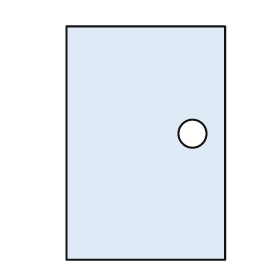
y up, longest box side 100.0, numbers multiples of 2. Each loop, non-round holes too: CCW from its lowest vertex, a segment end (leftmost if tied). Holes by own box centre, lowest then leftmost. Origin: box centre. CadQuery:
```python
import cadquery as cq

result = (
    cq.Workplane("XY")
    .moveTo(-34.0, -50.0)
    .lineTo(34.0, -50.0)
    .lineTo(34.0, 50.0)
    .lineTo(-34.0, 50.0)
    .close()
    .moveTo(20.0, 4.0)
    .circle(6.0)
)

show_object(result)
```